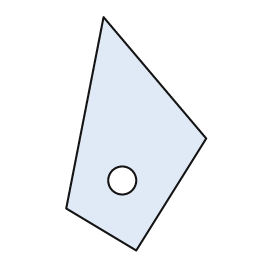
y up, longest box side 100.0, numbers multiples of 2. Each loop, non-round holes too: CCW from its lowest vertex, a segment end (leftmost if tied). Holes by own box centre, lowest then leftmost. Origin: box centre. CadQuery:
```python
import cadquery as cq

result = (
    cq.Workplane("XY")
    .moveTo(0.0, -50.0)
    .lineTo(30.0, -2.0)
    .lineTo(-14.0, 50.0)
    .lineTo(-30.0, -32.0)
    .close()
    .moveTo(-6.0, -20.0)
    .circle(6.0)
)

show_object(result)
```